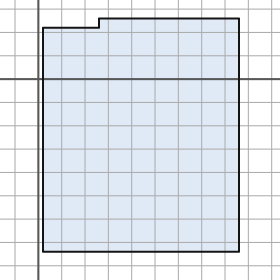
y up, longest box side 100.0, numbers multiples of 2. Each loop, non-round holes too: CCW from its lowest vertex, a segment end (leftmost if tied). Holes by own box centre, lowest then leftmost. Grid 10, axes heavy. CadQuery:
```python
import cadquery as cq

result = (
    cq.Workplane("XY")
    .moveTo(2.0, -74.0)
    .lineTo(86.0, -74.0)
    .lineTo(86.0, 26.0)
    .lineTo(26.0, 26.0)
    .lineTo(26.0, 22.0)
    .lineTo(2.0, 22.0)
    .close()
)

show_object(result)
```